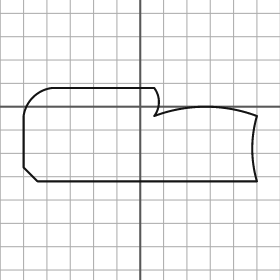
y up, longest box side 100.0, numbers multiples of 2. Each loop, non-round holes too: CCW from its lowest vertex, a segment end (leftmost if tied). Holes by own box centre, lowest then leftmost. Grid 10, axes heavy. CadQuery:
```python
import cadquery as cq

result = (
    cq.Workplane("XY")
    .moveTo(-44.0, -32.0)
    .lineTo(50.0, -32.0)
    .threePointArc((48.0, -18.0), (50.0, -4.0))
    .threePointArc((28.0, 0.0), (6.0, -4.0))
    .threePointArc((8.0, 2.0), (6.0, 8.0))
    .lineTo(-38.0, 8.0)
    .threePointArc((-46.0, 4.0), (-50.0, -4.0))
    .lineTo(-50.0, -26.0)
    .close()
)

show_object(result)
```